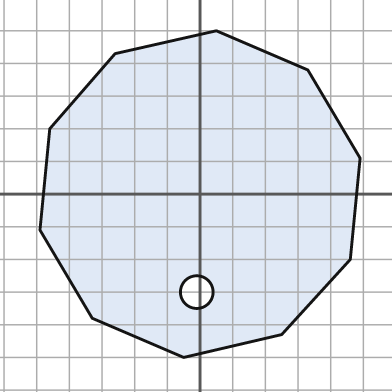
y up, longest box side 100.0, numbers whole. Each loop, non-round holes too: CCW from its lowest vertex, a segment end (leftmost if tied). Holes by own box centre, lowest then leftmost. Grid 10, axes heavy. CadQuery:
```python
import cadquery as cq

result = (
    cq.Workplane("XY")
    .moveTo(-5.0, -50.0)
    .lineTo(25.0, -43.0)
    .lineTo(46.0, -20.0)
    .lineTo(49.0, 11.0)
    .lineTo(33.0, 38.0)
    .lineTo(5.0, 50.0)
    .lineTo(-26.0, 43.0)
    .lineTo(-46.0, 20.0)
    .lineTo(-49.0, -11.0)
    .lineTo(-33.0, -38.0)
    .close()
    .moveTo(-1.0, -30.0)
    .circle(5.0)
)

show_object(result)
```